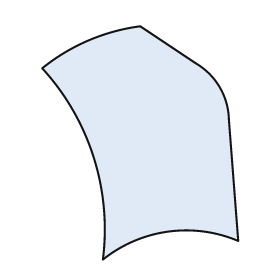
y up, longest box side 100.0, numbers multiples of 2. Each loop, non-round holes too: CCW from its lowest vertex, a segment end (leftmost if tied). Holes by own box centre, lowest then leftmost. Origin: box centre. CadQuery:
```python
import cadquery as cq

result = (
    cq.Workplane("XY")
    .moveTo(-16.0, -50.0)
    .threePointArc((12.0, -38.0), (42.0, -42.0))
    .lineTo(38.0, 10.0)
    .threePointArc((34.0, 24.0), (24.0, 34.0))
    .lineTo(0.0, 50.0)
    .threePointArc((-22.0, 44.0), (-42.0, 32.0))
    .threePointArc((-20.0, -6.0), (-16.0, -50.0))
    .close()
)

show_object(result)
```